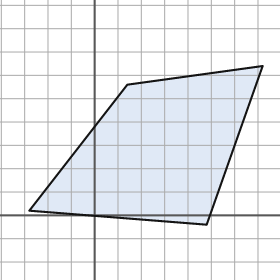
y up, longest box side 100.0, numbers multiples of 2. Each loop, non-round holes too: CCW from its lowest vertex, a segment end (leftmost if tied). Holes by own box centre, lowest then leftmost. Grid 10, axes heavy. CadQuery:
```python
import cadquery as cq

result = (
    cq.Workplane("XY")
    .moveTo(48.0, -4.0)
    .lineTo(72.0, 64.0)
    .lineTo(14.0, 56.0)
    .lineTo(-28.0, 2.0)
    .close()
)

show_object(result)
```